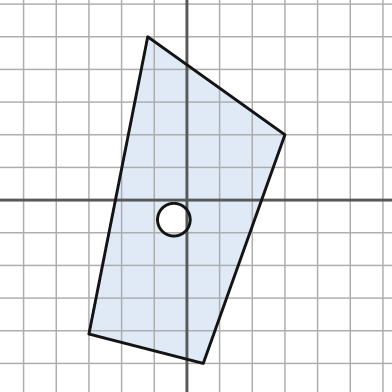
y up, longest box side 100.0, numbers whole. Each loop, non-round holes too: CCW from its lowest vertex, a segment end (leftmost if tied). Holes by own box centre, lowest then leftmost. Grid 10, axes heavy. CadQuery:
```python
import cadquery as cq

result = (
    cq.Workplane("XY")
    .moveTo(5.0, -50.0)
    .lineTo(30.0, 20.0)
    .lineTo(-12.0, 50.0)
    .lineTo(-30.0, -41.0)
    .close()
    .moveTo(-4.0, -6.0)
    .circle(5.0)
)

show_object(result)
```